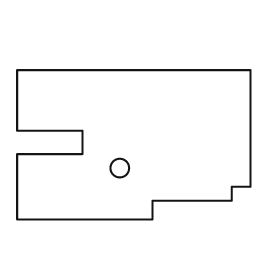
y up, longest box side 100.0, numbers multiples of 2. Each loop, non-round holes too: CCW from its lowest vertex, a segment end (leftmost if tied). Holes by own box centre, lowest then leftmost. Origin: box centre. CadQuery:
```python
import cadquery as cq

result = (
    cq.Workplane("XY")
    .moveTo(-50.0, -32.0)
    .lineTo(8.0, -32.0)
    .lineTo(8.0, -24.0)
    .lineTo(42.0, -24.0)
    .lineTo(42.0, -18.0)
    .lineTo(50.0, -18.0)
    .lineTo(50.0, 32.0)
    .lineTo(-50.0, 32.0)
    .lineTo(-50.0, 6.0)
    .lineTo(-22.0, 6.0)
    .lineTo(-22.0, -4.0)
    .lineTo(-50.0, -4.0)
    .close()
    .moveTo(-6.0, -10.0)
    .circle(4.0)
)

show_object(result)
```